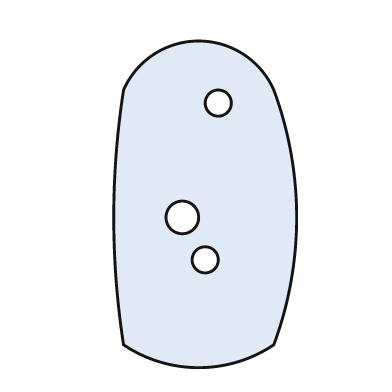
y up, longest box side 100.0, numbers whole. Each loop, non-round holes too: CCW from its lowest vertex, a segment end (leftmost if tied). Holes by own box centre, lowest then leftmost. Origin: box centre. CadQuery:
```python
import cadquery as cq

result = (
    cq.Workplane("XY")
    .moveTo(-25.0, -43.0)
    .threePointArc((-2.0, -50.0), (21.0, -43.0))
    .threePointArc((28.0, -4.0), (21.0, 35.0))
    .threePointArc((-2.0, 50.0), (-25.0, 35.0))
    .threePointArc((-28.0, -4.0), (-25.0, -43.0))
    .close()
    .moveTo(0.0, -17.0)
    .circle(4.0)
    .moveTo(-7.0, -4.0)
    .circle(5.0)
    .moveTo(4.0, 31.0)
    .circle(4.0)
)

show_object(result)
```